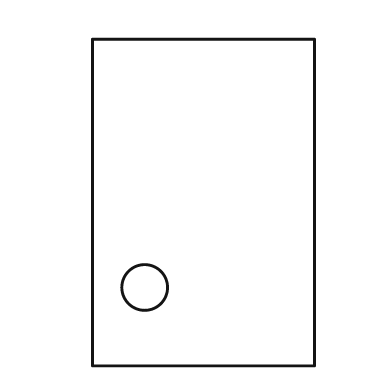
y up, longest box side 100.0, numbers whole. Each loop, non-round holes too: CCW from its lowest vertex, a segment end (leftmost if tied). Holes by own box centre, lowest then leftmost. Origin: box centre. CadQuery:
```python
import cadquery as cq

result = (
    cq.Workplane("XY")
    .moveTo(-34.0, -50.0)
    .lineTo(34.0, -50.0)
    .lineTo(34.0, 50.0)
    .lineTo(-34.0, 50.0)
    .close()
    .moveTo(-18.0, -26.0)
    .circle(7.0)
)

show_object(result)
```